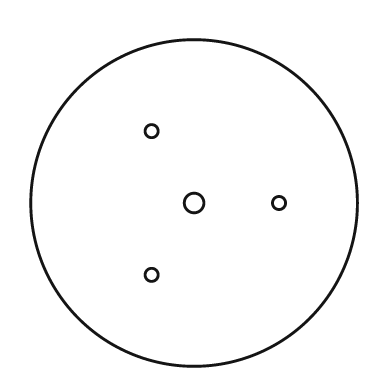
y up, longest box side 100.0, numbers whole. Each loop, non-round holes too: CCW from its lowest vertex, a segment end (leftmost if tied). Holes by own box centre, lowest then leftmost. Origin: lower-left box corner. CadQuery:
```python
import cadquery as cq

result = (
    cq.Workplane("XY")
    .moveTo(50.0, 50.0)
    .circle(50.0)
    .moveTo(37.0, 28.0)
    .circle(2.0)
    .moveTo(50.0, 50.0)
    .circle(3.0)
    .moveTo(76.0, 50.0)
    .circle(2.0)
    .moveTo(37.0, 72.0)
    .circle(2.0)
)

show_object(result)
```